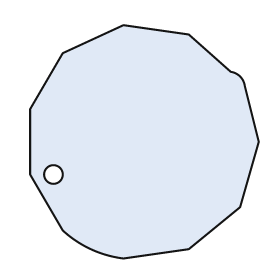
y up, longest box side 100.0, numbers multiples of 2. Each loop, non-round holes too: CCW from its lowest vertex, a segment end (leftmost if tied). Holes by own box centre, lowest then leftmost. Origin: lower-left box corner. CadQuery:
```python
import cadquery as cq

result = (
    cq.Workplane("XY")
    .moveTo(40.0, 0.0)
    .lineTo(68.0, 4.0)
    .lineTo(90.0, 22.0)
    .lineTo(98.0, 50.0)
    .lineTo(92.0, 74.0)
    .threePointArc((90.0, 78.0), (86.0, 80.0))
    .lineTo(68.0, 96.0)
    .lineTo(40.0, 100.0)
    .lineTo(14.0, 88.0)
    .lineTo(0.0, 64.0)
    .lineTo(0.0, 36.0)
    .lineTo(14.0, 12.0)
    .threePointArc((26.0, 4.0), (40.0, 0.0))
    .close()
    .moveTo(10.0, 36.0)
    .circle(4.0)
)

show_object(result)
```